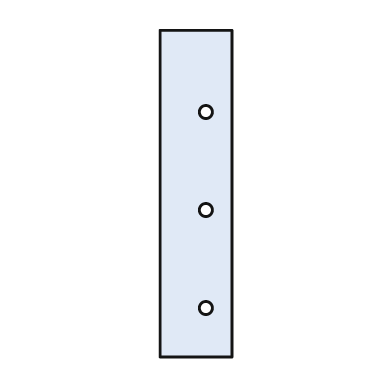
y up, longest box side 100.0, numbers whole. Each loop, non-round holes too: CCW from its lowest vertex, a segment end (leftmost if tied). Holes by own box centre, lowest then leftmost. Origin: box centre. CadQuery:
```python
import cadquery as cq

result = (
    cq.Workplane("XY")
    .moveTo(-11.0, -50.0)
    .lineTo(11.0, -50.0)
    .lineTo(11.0, 50.0)
    .lineTo(-11.0, 50.0)
    .close()
    .moveTo(3.0, -35.0)
    .circle(2.0)
    .moveTo(3.0, -5.0)
    .circle(2.0)
    .moveTo(3.0, 25.0)
    .circle(2.0)
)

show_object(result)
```